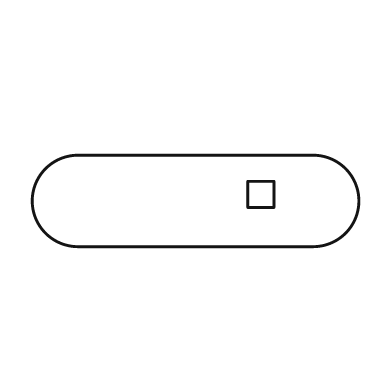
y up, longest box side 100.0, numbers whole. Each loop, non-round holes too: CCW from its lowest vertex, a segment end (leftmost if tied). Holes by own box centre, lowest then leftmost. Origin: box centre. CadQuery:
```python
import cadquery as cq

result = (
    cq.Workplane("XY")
    .moveTo(-36.0, -14.0)
    .lineTo(36.0, -14.0)
    .threePointArc((50.0, 0.0), (36.0, 14.0))
    .lineTo(-36.0, 14.0)
    .threePointArc((-50.0, 0.0), (-36.0, -14.0))
    .close()
    .moveTo(16.0, -2.0)
    .lineTo(24.0, -2.0)
    .lineTo(24.0, 6.0)
    .lineTo(16.0, 6.0)
    .close()
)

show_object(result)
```